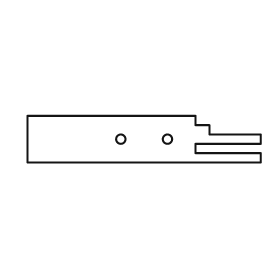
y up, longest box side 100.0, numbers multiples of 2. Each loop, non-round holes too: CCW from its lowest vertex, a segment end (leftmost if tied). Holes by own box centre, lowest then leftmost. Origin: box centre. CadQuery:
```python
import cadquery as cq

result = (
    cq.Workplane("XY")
    .moveTo(-50.0, -10.0)
    .lineTo(50.0, -10.0)
    .lineTo(50.0, -6.0)
    .lineTo(22.0, -6.0)
    .lineTo(22.0, -2.0)
    .lineTo(50.0, -2.0)
    .lineTo(50.0, 2.0)
    .lineTo(28.0, 2.0)
    .lineTo(28.0, 6.0)
    .lineTo(22.0, 6.0)
    .lineTo(22.0, 10.0)
    .lineTo(-50.0, 10.0)
    .close()
    .moveTo(-10.0, 0.0)
    .circle(2.0)
    .moveTo(10.0, 0.0)
    .circle(2.0)
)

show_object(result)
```